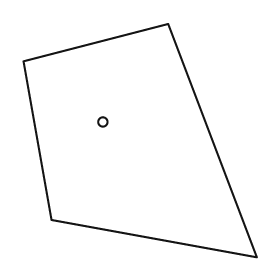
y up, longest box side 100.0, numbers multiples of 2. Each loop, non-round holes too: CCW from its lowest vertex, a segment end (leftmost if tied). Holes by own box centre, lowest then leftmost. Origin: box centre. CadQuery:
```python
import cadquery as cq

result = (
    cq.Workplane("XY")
    .moveTo(50.0, -50.0)
    .lineTo(12.0, 50.0)
    .lineTo(-50.0, 34.0)
    .lineTo(-38.0, -34.0)
    .close()
    .moveTo(-16.0, 8.0)
    .circle(2.0)
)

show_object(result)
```